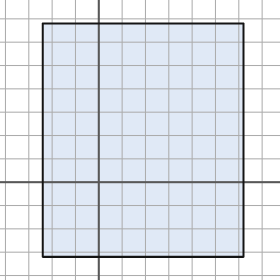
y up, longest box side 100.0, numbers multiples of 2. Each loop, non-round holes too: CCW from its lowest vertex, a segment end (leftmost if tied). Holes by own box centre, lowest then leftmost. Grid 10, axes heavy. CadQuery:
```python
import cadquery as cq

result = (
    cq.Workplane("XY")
    .moveTo(-24.0, -32.0)
    .lineTo(62.0, -32.0)
    .lineTo(62.0, 68.0)
    .lineTo(-24.0, 68.0)
    .close()
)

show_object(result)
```